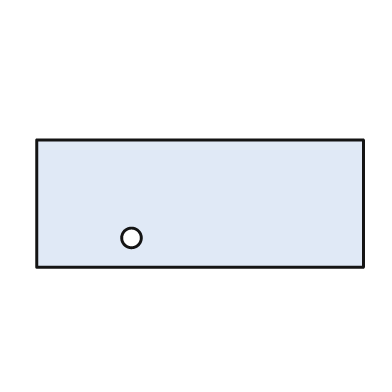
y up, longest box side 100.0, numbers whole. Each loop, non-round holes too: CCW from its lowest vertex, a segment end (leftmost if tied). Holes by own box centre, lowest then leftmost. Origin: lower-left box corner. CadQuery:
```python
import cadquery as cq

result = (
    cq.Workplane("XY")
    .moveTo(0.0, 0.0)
    .lineTo(100.0, 0.0)
    .lineTo(100.0, 39.0)
    .lineTo(0.0, 39.0)
    .close()
    .moveTo(29.0, 9.0)
    .circle(3.0)
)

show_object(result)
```